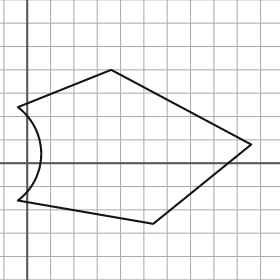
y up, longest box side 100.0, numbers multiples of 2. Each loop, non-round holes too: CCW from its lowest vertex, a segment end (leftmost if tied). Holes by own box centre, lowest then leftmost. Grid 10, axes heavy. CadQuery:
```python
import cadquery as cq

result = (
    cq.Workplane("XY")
    .moveTo(54.0, -26.0)
    .lineTo(96.0, 8.0)
    .lineTo(36.0, 40.0)
    .lineTo(-4.0, 24.0)
    .threePointArc((6.0, 4.0), (-4.0, -16.0))
    .close()
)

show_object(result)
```